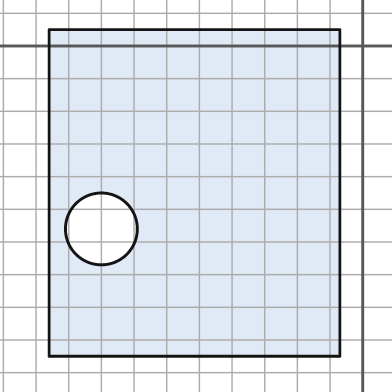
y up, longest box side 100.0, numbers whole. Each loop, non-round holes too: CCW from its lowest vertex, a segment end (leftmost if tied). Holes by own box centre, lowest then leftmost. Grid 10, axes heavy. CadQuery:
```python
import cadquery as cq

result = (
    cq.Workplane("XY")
    .moveTo(-96.0, -95.0)
    .lineTo(-7.0, -95.0)
    .lineTo(-7.0, 5.0)
    .lineTo(-96.0, 5.0)
    .close()
    .moveTo(-80.0, -56.0)
    .circle(11.0)
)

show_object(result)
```